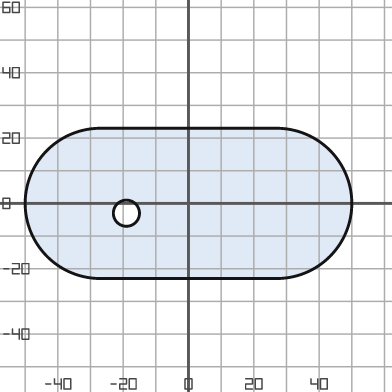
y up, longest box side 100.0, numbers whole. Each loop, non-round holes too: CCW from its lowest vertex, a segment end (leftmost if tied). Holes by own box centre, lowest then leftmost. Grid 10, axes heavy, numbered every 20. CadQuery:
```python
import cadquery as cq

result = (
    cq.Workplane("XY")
    .moveTo(-27.0, -23.0)
    .lineTo(27.0, -23.0)
    .threePointArc((50.0, 0.0), (27.0, 23.0))
    .lineTo(-27.0, 23.0)
    .threePointArc((-50.0, 0.0), (-27.0, -23.0))
    .close()
    .moveTo(-19.0, -3.0)
    .circle(4.0)
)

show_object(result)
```